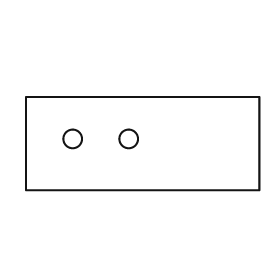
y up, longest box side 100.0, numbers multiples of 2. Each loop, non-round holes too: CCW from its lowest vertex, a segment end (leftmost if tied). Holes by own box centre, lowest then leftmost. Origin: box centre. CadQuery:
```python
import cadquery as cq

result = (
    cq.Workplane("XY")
    .moveTo(-50.0, -20.0)
    .lineTo(50.0, -20.0)
    .lineTo(50.0, 20.0)
    .lineTo(-50.0, 20.0)
    .close()
    .moveTo(-30.0, 2.0)
    .circle(4.0)
    .moveTo(-6.0, 2.0)
    .circle(4.0)
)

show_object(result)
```